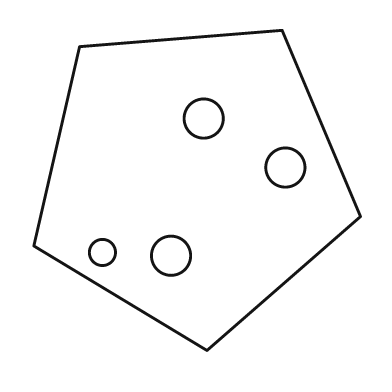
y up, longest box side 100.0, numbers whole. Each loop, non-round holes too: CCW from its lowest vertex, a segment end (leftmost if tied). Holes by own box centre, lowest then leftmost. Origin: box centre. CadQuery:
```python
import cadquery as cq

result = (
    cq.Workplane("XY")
    .moveTo(3.0, -49.0)
    .lineTo(50.0, -8.0)
    .lineTo(26.0, 49.0)
    .lineTo(-36.0, 44.0)
    .lineTo(-50.0, -17.0)
    .close()
    .moveTo(-8.0, -20.0)
    .circle(6.0)
    .moveTo(-29.0, -19.0)
    .circle(4.0)
    .moveTo(27.0, 7.0)
    .circle(6.0)
    .moveTo(2.0, 22.0)
    .circle(6.0)
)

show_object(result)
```